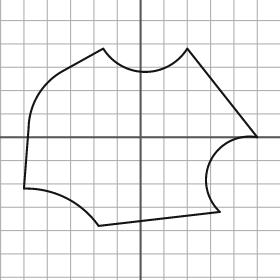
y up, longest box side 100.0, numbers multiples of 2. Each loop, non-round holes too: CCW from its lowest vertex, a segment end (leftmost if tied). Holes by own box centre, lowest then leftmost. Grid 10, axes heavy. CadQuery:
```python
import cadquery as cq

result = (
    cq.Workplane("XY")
    .moveTo(-18.0, -38.0)
    .lineTo(34.0, -32.0)
    .threePointArc((30.0, -10.0), (50.0, 0.0))
    .lineTo(20.0, 38.0)
    .threePointArc((2.0, 28.0), (-16.0, 38.0))
    .lineTo(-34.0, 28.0)
    .threePointArc((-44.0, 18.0), (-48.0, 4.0))
    .lineTo(-50.0, -22.0)
    .threePointArc((-32.0, -26.0), (-18.0, -38.0))
    .close()
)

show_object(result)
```